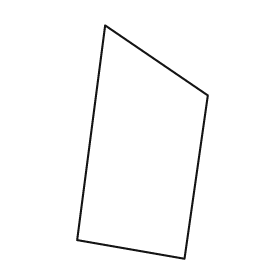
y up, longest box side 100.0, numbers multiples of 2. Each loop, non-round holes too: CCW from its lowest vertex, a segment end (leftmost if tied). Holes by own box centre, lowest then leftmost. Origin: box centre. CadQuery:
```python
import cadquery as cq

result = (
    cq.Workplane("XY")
    .moveTo(18.0, -50.0)
    .lineTo(28.0, 20.0)
    .lineTo(-16.0, 50.0)
    .lineTo(-28.0, -42.0)
    .close()
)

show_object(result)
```